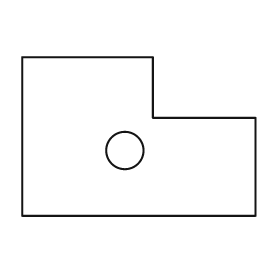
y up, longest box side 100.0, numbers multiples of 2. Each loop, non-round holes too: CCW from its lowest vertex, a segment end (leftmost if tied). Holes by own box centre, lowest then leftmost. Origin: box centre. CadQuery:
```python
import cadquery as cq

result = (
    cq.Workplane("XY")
    .moveTo(-50.0, -34.0)
    .lineTo(50.0, -34.0)
    .lineTo(50.0, 8.0)
    .lineTo(6.0, 8.0)
    .lineTo(6.0, 34.0)
    .lineTo(-50.0, 34.0)
    .close()
    .moveTo(-6.0, -6.0)
    .circle(8.0)
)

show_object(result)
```